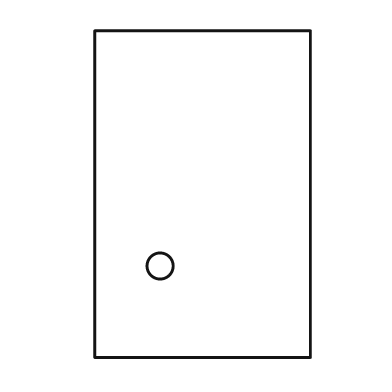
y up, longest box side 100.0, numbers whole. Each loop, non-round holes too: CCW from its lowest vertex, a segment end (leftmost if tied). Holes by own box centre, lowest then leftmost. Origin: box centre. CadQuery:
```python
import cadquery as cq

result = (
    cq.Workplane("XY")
    .moveTo(-33.0, -50.0)
    .lineTo(33.0, -50.0)
    .lineTo(33.0, 50.0)
    .lineTo(-33.0, 50.0)
    .close()
    .moveTo(-13.0, -22.0)
    .circle(4.0)
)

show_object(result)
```